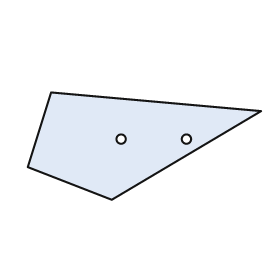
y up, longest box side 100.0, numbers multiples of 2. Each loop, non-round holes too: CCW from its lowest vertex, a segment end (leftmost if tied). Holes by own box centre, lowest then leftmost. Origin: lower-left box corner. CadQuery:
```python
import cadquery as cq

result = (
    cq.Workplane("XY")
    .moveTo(36.0, 0.0)
    .lineTo(100.0, 38.0)
    .lineTo(10.0, 46.0)
    .lineTo(0.0, 14.0)
    .close()
    .moveTo(40.0, 26.0)
    .circle(2.0)
    .moveTo(68.0, 26.0)
    .circle(2.0)
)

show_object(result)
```